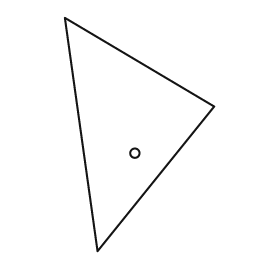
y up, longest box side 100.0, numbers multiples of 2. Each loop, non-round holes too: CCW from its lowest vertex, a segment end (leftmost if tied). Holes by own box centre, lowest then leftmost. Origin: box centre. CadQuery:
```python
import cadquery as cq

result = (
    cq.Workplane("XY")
    .moveTo(-18.0, -50.0)
    .lineTo(32.0, 12.0)
    .lineTo(-32.0, 50.0)
    .close()
    .moveTo(-2.0, -8.0)
    .circle(2.0)
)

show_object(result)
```